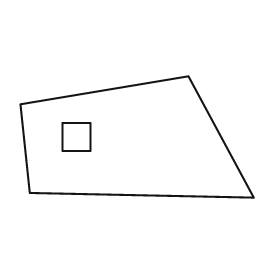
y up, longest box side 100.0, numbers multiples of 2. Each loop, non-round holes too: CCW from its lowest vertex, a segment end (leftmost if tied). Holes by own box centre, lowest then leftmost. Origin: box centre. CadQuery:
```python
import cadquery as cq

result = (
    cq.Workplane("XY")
    .moveTo(50.0, -26.0)
    .lineTo(22.0, 26.0)
    .lineTo(-50.0, 14.0)
    .lineTo(-46.0, -24.0)
    .close()
    .moveTo(-32.0, -6.0)
    .lineTo(-20.0, -6.0)
    .lineTo(-20.0, 6.0)
    .lineTo(-32.0, 6.0)
    .close()
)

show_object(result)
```